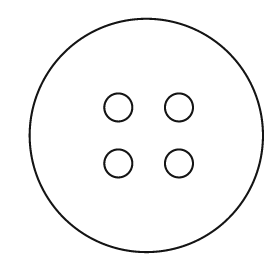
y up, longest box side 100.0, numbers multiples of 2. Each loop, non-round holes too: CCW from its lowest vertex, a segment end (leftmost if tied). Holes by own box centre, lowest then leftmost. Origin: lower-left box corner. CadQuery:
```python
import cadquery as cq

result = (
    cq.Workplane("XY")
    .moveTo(50.0, 50.0)
    .circle(50.0)
    .moveTo(38.0, 38.0)
    .circle(6.0)
    .moveTo(64.0, 38.0)
    .circle(6.0)
    .moveTo(38.0, 62.0)
    .circle(6.0)
    .moveTo(64.0, 62.0)
    .circle(6.0)
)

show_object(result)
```